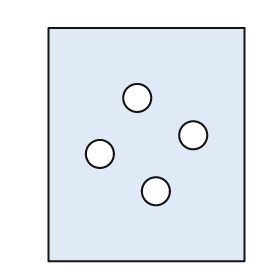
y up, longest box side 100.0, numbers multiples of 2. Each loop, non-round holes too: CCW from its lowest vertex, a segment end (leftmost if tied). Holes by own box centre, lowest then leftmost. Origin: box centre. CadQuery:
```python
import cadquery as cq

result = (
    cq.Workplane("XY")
    .moveTo(-42.0, -50.0)
    .lineTo(42.0, -50.0)
    .lineTo(42.0, 50.0)
    .lineTo(-42.0, 50.0)
    .close()
    .moveTo(4.0, -20.0)
    .circle(6.0)
    .moveTo(-20.0, -4.0)
    .circle(6.0)
    .moveTo(20.0, 4.0)
    .circle(6.0)
    .moveTo(-4.0, 20.0)
    .circle(6.0)
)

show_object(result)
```